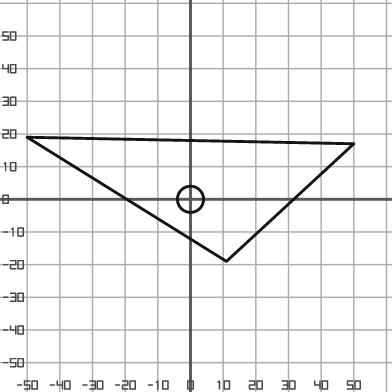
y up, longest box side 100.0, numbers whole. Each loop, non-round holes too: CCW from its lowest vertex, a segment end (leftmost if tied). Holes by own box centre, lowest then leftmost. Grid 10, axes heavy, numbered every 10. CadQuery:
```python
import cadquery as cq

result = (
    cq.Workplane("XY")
    .moveTo(11.0, -19.0)
    .lineTo(50.0, 17.0)
    .lineTo(-50.0, 19.0)
    .close()
    .moveTo(0.0, 0.0)
    .circle(4.0)
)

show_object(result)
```